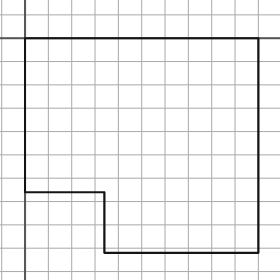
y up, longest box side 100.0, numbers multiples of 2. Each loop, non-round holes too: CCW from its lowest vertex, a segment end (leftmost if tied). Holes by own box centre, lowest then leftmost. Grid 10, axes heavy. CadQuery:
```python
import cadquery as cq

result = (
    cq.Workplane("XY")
    .moveTo(34.0, -92.0)
    .lineTo(100.0, -92.0)
    .lineTo(100.0, 0.0)
    .lineTo(0.0, 0.0)
    .lineTo(0.0, -66.0)
    .lineTo(34.0, -66.0)
    .close()
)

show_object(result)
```